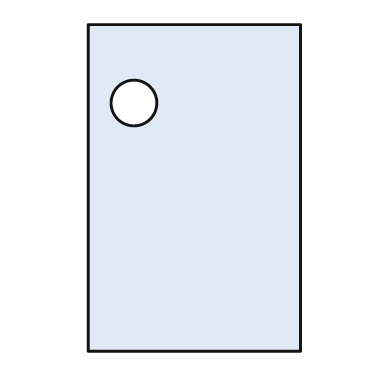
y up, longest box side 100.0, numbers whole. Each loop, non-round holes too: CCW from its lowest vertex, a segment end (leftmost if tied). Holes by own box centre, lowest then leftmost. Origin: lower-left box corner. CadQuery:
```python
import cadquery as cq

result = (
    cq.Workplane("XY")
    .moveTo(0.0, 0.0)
    .lineTo(65.0, 0.0)
    .lineTo(65.0, 100.0)
    .lineTo(0.0, 100.0)
    .close()
    .moveTo(14.0, 76.0)
    .circle(7.0)
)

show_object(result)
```